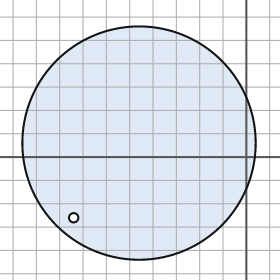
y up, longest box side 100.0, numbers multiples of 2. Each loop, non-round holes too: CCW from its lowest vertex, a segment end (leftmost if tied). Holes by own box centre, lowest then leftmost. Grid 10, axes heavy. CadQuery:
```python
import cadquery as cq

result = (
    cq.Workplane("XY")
    .moveTo(-46.0, 6.0)
    .circle(50.0)
    .moveTo(-74.0, -26.0)
    .circle(2.0)
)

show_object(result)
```